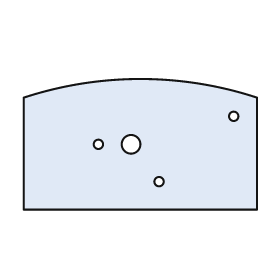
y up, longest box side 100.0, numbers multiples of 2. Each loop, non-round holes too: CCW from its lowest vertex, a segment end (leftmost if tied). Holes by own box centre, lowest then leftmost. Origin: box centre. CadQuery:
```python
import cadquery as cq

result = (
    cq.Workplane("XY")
    .moveTo(-50.0, -28.0)
    .lineTo(50.0, -28.0)
    .lineTo(50.0, 20.0)
    .threePointArc((0.0, 28.0), (-50.0, 20.0))
    .close()
    .moveTo(8.0, -16.0)
    .circle(2.0)
    .moveTo(-18.0, 0.0)
    .circle(2.0)
    .moveTo(-4.0, 0.0)
    .circle(4.0)
    .moveTo(40.0, 12.0)
    .circle(2.0)
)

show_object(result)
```